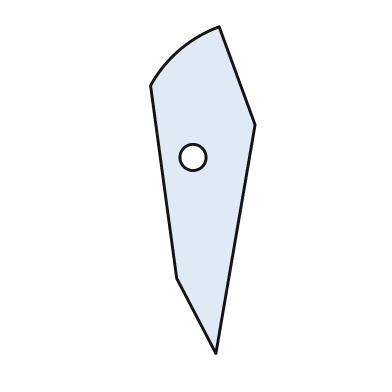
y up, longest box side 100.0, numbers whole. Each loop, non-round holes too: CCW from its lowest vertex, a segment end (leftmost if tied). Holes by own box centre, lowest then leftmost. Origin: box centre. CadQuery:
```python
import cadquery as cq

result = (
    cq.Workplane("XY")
    .moveTo(4.0, -50.0)
    .lineTo(16.0, 20.0)
    .lineTo(5.0, 50.0)
    .threePointArc((-7.0, 43.0), (-16.0, 32.0))
    .lineTo(-8.0, -27.0)
    .close()
    .moveTo(-3.0, 10.0)
    .circle(4.0)
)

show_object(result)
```